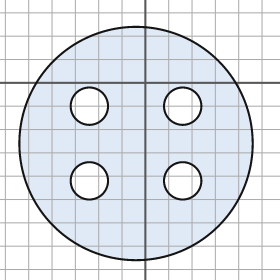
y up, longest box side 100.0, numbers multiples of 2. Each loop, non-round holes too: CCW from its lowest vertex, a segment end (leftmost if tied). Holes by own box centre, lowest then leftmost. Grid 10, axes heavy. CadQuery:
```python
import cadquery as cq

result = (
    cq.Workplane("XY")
    .moveTo(-4.0, -26.0)
    .circle(50.0)
    .moveTo(-24.0, -42.0)
    .circle(8.0)
    .moveTo(16.0, -42.0)
    .circle(8.0)
    .moveTo(-24.0, -10.0)
    .circle(8.0)
    .moveTo(16.0, -10.0)
    .circle(8.0)
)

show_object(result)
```